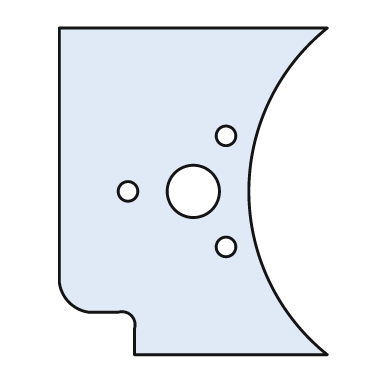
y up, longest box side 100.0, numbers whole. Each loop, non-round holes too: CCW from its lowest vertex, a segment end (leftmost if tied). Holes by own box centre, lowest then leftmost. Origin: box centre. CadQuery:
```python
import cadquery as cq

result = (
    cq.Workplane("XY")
    .moveTo(-18.0, -50.0)
    .lineTo(41.0, -50.0)
    .threePointArc((17.0, 0.0), (41.0, 50.0))
    .lineTo(-41.0, 50.0)
    .lineTo(-41.0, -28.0)
    .threePointArc((-38.0, -34.0), (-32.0, -37.0))
    .lineTo(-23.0, -37.0)
    .threePointArc((-19.0, -38.0), (-18.0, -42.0))
    .close()
    .moveTo(10.0, -17.0)
    .circle(3.0)
    .moveTo(-20.0, 0.0)
    .circle(3.0)
    .moveTo(0.0, 0.0)
    .circle(8.0)
    .moveTo(10.0, 17.0)
    .circle(3.0)
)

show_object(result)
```